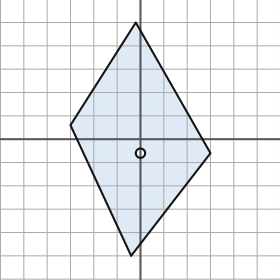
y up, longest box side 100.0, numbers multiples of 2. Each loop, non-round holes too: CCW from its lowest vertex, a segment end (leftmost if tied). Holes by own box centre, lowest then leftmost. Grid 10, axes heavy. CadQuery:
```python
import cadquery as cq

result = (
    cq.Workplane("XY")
    .moveTo(-4.0, -50.0)
    .lineTo(30.0, -6.0)
    .lineTo(-2.0, 50.0)
    .lineTo(-30.0, 6.0)
    .close()
    .moveTo(0.0, -6.0)
    .circle(2.0)
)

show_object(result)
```